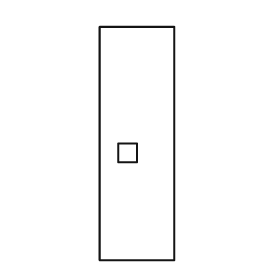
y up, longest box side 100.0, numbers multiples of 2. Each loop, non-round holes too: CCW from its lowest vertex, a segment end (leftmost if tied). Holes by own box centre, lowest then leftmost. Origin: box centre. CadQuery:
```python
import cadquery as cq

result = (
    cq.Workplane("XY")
    .moveTo(-16.0, -50.0)
    .lineTo(16.0, -50.0)
    .lineTo(16.0, 50.0)
    .lineTo(-16.0, 50.0)
    .close()
    .moveTo(-8.0, -8.0)
    .lineTo(0.0, -8.0)
    .lineTo(0.0, 0.0)
    .lineTo(-8.0, 0.0)
    .close()
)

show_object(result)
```